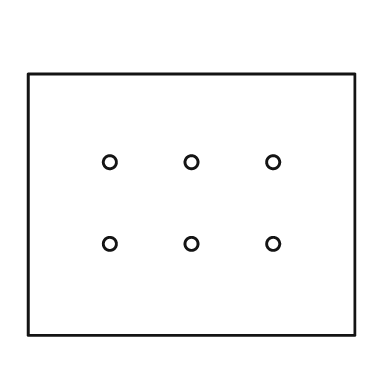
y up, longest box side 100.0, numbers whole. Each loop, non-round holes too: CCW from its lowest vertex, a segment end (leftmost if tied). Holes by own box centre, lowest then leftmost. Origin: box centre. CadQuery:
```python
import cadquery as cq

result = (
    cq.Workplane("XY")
    .moveTo(-50.0, -40.0)
    .lineTo(50.0, -40.0)
    .lineTo(50.0, 40.0)
    .lineTo(-50.0, 40.0)
    .close()
    .moveTo(-25.0, -12.0)
    .circle(2.0)
    .moveTo(0.0, -12.0)
    .circle(2.0)
    .moveTo(25.0, -12.0)
    .circle(2.0)
    .moveTo(-25.0, 13.0)
    .circle(2.0)
    .moveTo(0.0, 13.0)
    .circle(2.0)
    .moveTo(25.0, 13.0)
    .circle(2.0)
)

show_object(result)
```